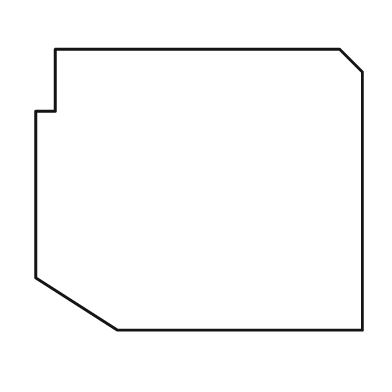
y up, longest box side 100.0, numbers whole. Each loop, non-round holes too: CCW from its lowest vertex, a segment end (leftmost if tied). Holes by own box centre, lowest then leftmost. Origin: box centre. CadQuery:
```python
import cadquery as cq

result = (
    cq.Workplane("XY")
    .moveTo(-25.0, -43.0)
    .lineTo(50.0, -43.0)
    .lineTo(50.0, 36.0)
    .lineTo(43.0, 43.0)
    .lineTo(-44.0, 43.0)
    .lineTo(-44.0, 24.0)
    .lineTo(-50.0, 24.0)
    .lineTo(-50.0, -27.0)
    .close()
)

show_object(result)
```